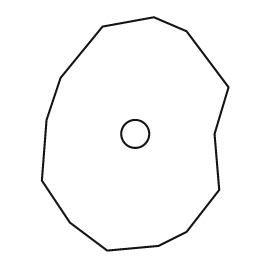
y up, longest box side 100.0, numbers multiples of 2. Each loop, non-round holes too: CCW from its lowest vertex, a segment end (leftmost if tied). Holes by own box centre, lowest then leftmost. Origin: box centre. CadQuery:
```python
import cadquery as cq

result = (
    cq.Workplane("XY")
    .moveTo(-12.0, -50.0)
    .lineTo(10.0, -48.0)
    .lineTo(22.0, -42.0)
    .lineTo(36.0, -24.0)
    .lineTo(34.0, 0.0)
    .lineTo(40.0, 20.0)
    .lineTo(22.0, 44.0)
    .lineTo(8.0, 50.0)
    .lineTo(-14.0, 46.0)
    .lineTo(-32.0, 24.0)
    .lineTo(-38.0, 6.0)
    .lineTo(-40.0, -20.0)
    .lineTo(-28.0, -38.0)
    .close()
    .moveTo(0.0, 0.0)
    .circle(6.0)
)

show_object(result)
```